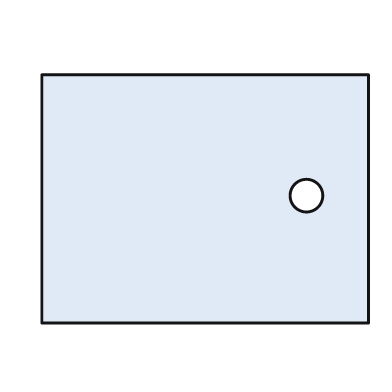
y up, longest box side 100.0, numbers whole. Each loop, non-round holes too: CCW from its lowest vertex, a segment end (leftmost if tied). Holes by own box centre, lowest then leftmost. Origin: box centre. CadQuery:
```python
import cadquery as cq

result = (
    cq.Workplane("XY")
    .moveTo(-50.0, -38.0)
    .lineTo(50.0, -38.0)
    .lineTo(50.0, 38.0)
    .lineTo(-50.0, 38.0)
    .close()
    .moveTo(31.0, 1.0)
    .circle(5.0)
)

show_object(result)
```